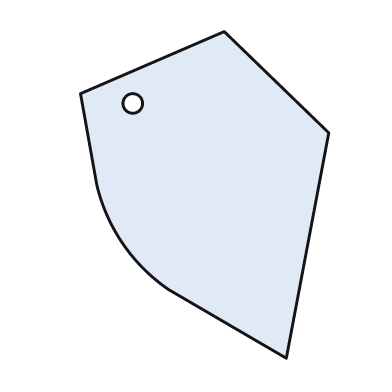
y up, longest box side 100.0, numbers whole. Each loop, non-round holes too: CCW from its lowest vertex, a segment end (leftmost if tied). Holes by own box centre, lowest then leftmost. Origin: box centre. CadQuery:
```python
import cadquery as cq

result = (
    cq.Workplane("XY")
    .moveTo(25.0, -50.0)
    .lineTo(38.0, 19.0)
    .lineTo(6.0, 50.0)
    .lineTo(-38.0, 31.0)
    .lineTo(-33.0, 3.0)
    .threePointArc((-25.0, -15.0), (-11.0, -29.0))
    .close()
    .moveTo(-22.0, 28.0)
    .circle(3.0)
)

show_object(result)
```